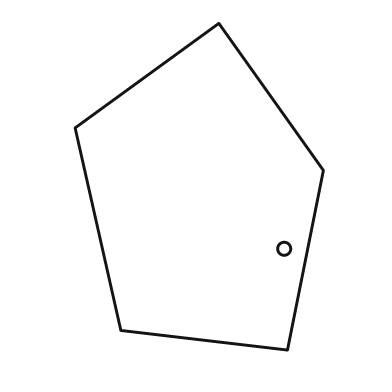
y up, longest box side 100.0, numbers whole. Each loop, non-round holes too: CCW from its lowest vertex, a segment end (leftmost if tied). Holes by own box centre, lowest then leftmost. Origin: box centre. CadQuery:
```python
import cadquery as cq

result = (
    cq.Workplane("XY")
    .moveTo(27.0, -50.0)
    .lineTo(38.0, 5.0)
    .lineTo(6.0, 50.0)
    .lineTo(-38.0, 18.0)
    .lineTo(-24.0, -44.0)
    .close()
    .moveTo(26.0, -19.0)
    .circle(2.0)
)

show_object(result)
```